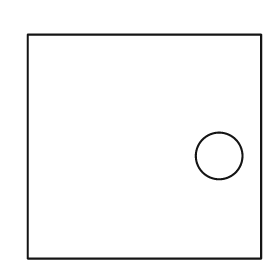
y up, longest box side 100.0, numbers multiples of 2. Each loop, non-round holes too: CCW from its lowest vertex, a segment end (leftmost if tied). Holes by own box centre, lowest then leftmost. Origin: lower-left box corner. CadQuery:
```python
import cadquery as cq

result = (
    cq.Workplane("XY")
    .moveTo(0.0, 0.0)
    .lineTo(100.0, 0.0)
    .lineTo(100.0, 96.0)
    .lineTo(0.0, 96.0)
    .close()
    .moveTo(82.0, 44.0)
    .circle(10.0)
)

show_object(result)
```